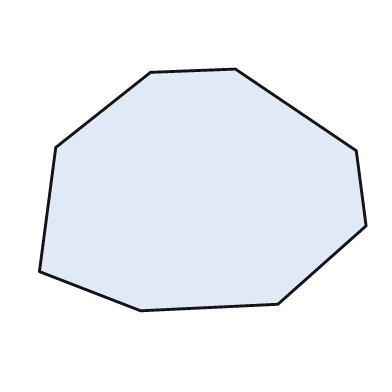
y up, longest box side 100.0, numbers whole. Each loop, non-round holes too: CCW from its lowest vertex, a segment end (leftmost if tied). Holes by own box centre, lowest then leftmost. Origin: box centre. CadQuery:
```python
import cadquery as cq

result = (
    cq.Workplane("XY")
    .moveTo(-19.0, -37.0)
    .lineTo(23.0, -35.0)
    .lineTo(50.0, -11.0)
    .lineTo(47.0, 12.0)
    .lineTo(10.0, 37.0)
    .lineTo(-16.0, 36.0)
    .lineTo(-45.0, 13.0)
    .lineTo(-50.0, -25.0)
    .close()
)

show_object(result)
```